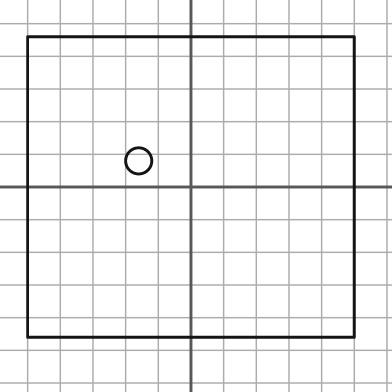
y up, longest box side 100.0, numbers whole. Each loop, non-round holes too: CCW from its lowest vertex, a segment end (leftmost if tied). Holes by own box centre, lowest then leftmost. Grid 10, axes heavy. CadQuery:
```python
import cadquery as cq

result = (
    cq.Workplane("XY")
    .moveTo(-50.0, -46.0)
    .lineTo(50.0, -46.0)
    .lineTo(50.0, 46.0)
    .lineTo(-50.0, 46.0)
    .close()
    .moveTo(-16.0, 8.0)
    .circle(4.0)
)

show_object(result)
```